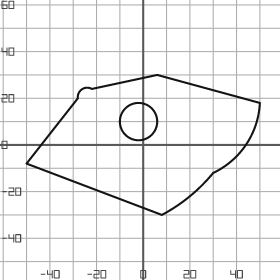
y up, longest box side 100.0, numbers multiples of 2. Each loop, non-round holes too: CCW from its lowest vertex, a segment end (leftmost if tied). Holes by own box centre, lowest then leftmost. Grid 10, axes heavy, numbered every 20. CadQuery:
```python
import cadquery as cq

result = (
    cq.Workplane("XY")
    .moveTo(8.0, -30.0)
    .threePointArc((20.0, -22.0), (30.0, -12.0))
    .threePointArc((44.0, 0.0), (50.0, 18.0))
    .lineTo(6.0, 30.0)
    .lineTo(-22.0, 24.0)
    .threePointArc((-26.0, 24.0), (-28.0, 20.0))
    .lineTo(-50.0, -8.0)
    .close()
    .moveTo(-2.0, 10.0)
    .circle(8.0)
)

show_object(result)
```